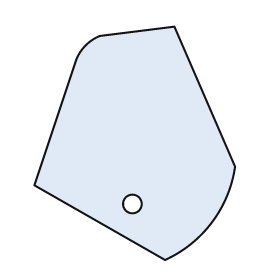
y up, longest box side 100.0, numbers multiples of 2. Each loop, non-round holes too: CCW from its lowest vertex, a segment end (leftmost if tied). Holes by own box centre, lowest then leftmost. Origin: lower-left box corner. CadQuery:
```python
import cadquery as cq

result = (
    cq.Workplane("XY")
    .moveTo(56.0, 0.0)
    .threePointArc((76.0, 16.0), (86.0, 40.0))
    .lineTo(60.0, 100.0)
    .lineTo(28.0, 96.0)
    .threePointArc((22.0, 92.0), (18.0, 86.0))
    .lineTo(0.0, 32.0)
    .close()
    .moveTo(42.0, 24.0)
    .circle(4.0)
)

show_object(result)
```